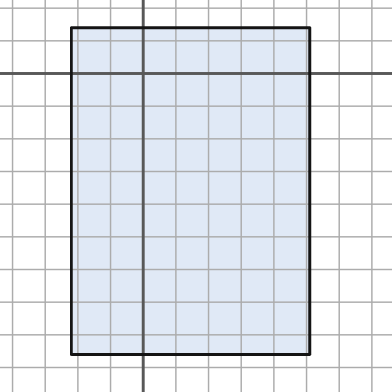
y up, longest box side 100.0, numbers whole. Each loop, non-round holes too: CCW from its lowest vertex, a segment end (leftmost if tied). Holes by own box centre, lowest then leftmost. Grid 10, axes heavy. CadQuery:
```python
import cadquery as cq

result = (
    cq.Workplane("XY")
    .moveTo(-22.0, -86.0)
    .lineTo(51.0, -86.0)
    .lineTo(51.0, 14.0)
    .lineTo(-22.0, 14.0)
    .close()
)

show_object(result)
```